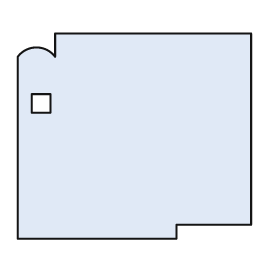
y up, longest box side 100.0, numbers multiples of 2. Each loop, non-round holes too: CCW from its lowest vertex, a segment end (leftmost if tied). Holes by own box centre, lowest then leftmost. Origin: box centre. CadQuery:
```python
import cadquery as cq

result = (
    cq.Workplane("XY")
    .moveTo(-50.0, -44.0)
    .lineTo(18.0, -44.0)
    .lineTo(18.0, -38.0)
    .lineTo(50.0, -38.0)
    .lineTo(50.0, 44.0)
    .lineTo(-34.0, 44.0)
    .lineTo(-34.0, 34.0)
    .threePointArc((-42.0, 38.0), (-50.0, 34.0))
    .close()
    .moveTo(-44.0, 10.0)
    .lineTo(-36.0, 10.0)
    .lineTo(-36.0, 18.0)
    .lineTo(-44.0, 18.0)
    .close()
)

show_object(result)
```